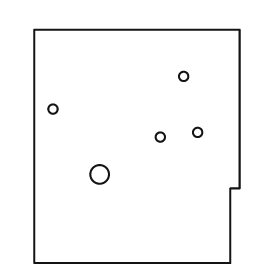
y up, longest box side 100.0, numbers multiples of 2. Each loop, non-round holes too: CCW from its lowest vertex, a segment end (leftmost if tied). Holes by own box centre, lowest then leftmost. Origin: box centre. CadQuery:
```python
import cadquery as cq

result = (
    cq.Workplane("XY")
    .moveTo(-44.0, -50.0)
    .lineTo(40.0, -50.0)
    .lineTo(40.0, -18.0)
    .lineTo(44.0, -18.0)
    .lineTo(44.0, 50.0)
    .lineTo(-44.0, 50.0)
    .close()
    .moveTo(-16.0, -12.0)
    .circle(4.0)
    .moveTo(10.0, 4.0)
    .circle(2.0)
    .moveTo(26.0, 6.0)
    .circle(2.0)
    .moveTo(-36.0, 16.0)
    .circle(2.0)
    .moveTo(20.0, 30.0)
    .circle(2.0)
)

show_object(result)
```